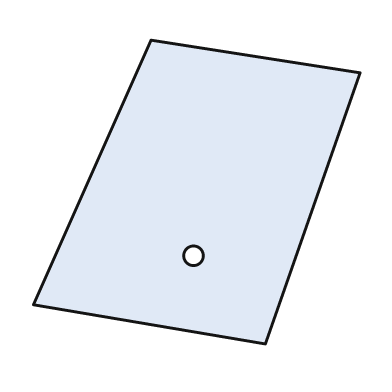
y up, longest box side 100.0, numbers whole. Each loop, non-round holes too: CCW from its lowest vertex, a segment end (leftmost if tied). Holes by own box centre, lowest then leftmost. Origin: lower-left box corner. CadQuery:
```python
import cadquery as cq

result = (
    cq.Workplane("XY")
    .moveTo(71.0, 0.0)
    .lineTo(100.0, 83.0)
    .lineTo(36.0, 93.0)
    .lineTo(0.0, 12.0)
    .close()
    .moveTo(49.0, 27.0)
    .circle(3.0)
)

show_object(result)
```